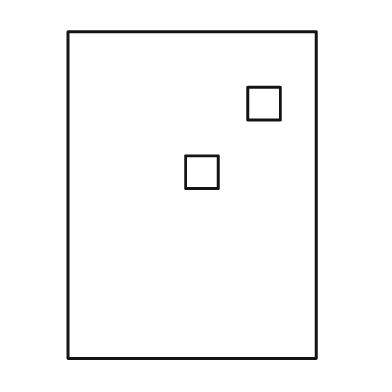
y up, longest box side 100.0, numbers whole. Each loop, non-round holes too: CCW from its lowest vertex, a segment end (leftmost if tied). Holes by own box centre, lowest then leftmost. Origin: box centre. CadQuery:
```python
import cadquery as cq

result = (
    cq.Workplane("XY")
    .moveTo(-38.0, -50.0)
    .lineTo(38.0, -50.0)
    .lineTo(38.0, 50.0)
    .lineTo(-38.0, 50.0)
    .close()
    .moveTo(-2.0, 2.0)
    .lineTo(8.0, 2.0)
    .lineTo(8.0, 12.0)
    .lineTo(-2.0, 12.0)
    .close()
    .moveTo(17.0, 23.0)
    .lineTo(27.0, 23.0)
    .lineTo(27.0, 33.0)
    .lineTo(17.0, 33.0)
    .close()
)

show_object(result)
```